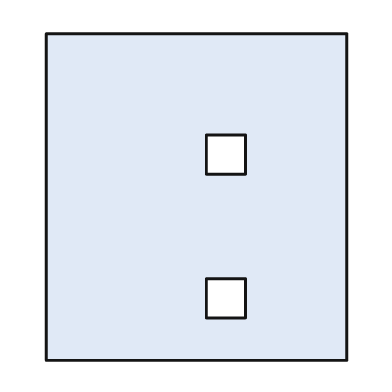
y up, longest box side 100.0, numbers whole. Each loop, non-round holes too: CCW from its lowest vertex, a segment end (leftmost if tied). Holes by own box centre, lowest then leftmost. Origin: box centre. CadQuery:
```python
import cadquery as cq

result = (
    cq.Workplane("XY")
    .moveTo(-46.0, -50.0)
    .lineTo(46.0, -50.0)
    .lineTo(46.0, 50.0)
    .lineTo(-46.0, 50.0)
    .close()
    .moveTo(3.0, -37.0)
    .lineTo(15.0, -37.0)
    .lineTo(15.0, -25.0)
    .lineTo(3.0, -25.0)
    .close()
    .moveTo(3.0, 7.0)
    .lineTo(15.0, 7.0)
    .lineTo(15.0, 19.0)
    .lineTo(3.0, 19.0)
    .close()
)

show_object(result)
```